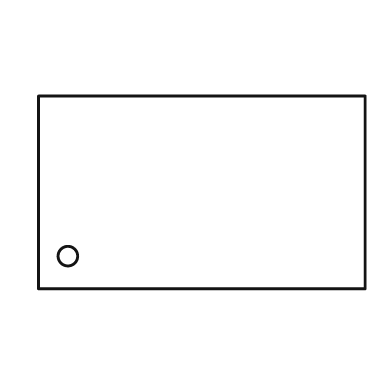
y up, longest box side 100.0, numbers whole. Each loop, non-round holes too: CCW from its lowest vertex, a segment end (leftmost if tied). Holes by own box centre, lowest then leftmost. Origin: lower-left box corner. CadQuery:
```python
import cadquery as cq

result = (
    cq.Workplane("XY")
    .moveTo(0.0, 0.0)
    .lineTo(100.0, 0.0)
    .lineTo(100.0, 59.0)
    .lineTo(0.0, 59.0)
    .close()
    .moveTo(9.0, 10.0)
    .circle(3.0)
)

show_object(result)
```